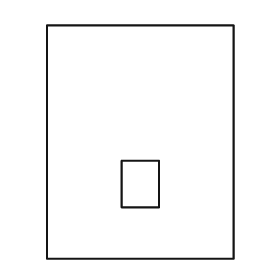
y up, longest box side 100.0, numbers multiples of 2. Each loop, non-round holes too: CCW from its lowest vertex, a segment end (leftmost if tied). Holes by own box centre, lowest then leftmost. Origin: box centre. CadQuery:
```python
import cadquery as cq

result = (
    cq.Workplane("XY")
    .moveTo(-40.0, -50.0)
    .lineTo(40.0, -50.0)
    .lineTo(40.0, 50.0)
    .lineTo(-40.0, 50.0)
    .close()
    .moveTo(-8.0, -28.0)
    .lineTo(8.0, -28.0)
    .lineTo(8.0, -8.0)
    .lineTo(-8.0, -8.0)
    .close()
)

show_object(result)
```